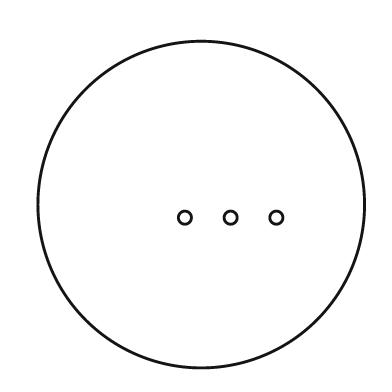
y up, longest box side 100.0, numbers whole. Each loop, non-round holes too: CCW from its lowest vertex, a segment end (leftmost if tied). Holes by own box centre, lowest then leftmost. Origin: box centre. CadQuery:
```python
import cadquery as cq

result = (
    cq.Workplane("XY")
    .moveTo(0.0, 0.0)
    .circle(50.0)
    .moveTo(-5.0, -4.0)
    .circle(2.0)
    .moveTo(9.0, -4.0)
    .circle(2.0)
    .moveTo(23.0, -4.0)
    .circle(2.0)
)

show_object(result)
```